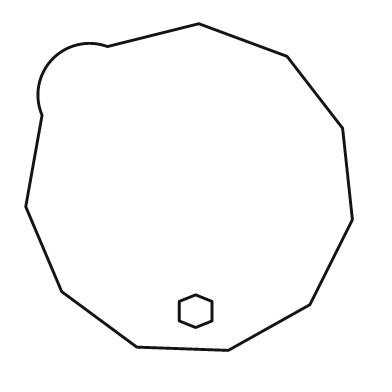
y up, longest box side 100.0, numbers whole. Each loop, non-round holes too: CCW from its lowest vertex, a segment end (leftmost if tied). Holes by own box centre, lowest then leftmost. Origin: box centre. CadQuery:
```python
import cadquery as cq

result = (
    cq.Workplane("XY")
    .moveTo(12.0, -50.0)
    .lineTo(37.0, -36.0)
    .lineTo(50.0, -10.0)
    .lineTo(47.0, 18.0)
    .lineTo(30.0, 40.0)
    .lineTo(3.0, 50.0)
    .lineTo(-25.0, 43.0)
    .threePointArc((-42.0, 39.0), (-45.0, 22.0))
    .lineTo(-50.0, -6.0)
    .lineTo(-39.0, -32.0)
    .lineTo(-16.0, -49.0)
    .close()
    .moveTo(2.0, -43.0)
    .lineTo(7.0, -41.0)
    .lineTo(7.0, -35.0)
    .lineTo(2.0, -33.0)
    .lineTo(-3.0, -35.0)
    .lineTo(-3.0, -41.0)
    .close()
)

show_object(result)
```